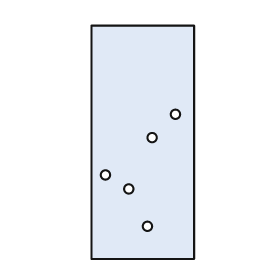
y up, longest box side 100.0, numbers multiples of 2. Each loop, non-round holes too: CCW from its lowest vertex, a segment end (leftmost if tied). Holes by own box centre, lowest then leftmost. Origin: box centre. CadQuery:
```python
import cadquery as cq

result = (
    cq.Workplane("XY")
    .moveTo(-22.0, -50.0)
    .lineTo(22.0, -50.0)
    .lineTo(22.0, 50.0)
    .lineTo(-22.0, 50.0)
    .close()
    .moveTo(2.0, -36.0)
    .circle(2.0)
    .moveTo(-6.0, -20.0)
    .circle(2.0)
    .moveTo(-16.0, -14.0)
    .circle(2.0)
    .moveTo(4.0, 2.0)
    .circle(2.0)
    .moveTo(14.0, 12.0)
    .circle(2.0)
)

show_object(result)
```